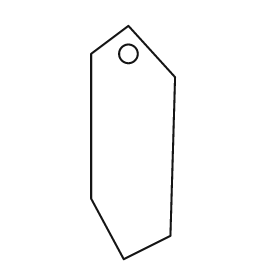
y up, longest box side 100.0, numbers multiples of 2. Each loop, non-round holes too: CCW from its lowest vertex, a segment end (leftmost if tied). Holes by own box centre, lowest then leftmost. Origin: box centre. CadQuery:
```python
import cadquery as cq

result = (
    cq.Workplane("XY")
    .moveTo(-4.0, -50.0)
    .lineTo(16.0, -40.0)
    .lineTo(18.0, 28.0)
    .lineTo(-2.0, 50.0)
    .lineTo(-18.0, 38.0)
    .lineTo(-18.0, -24.0)
    .close()
    .moveTo(-2.0, 38.0)
    .circle(4.0)
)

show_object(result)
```